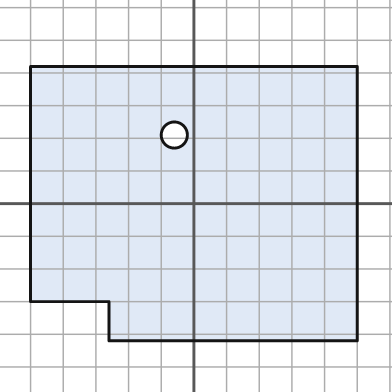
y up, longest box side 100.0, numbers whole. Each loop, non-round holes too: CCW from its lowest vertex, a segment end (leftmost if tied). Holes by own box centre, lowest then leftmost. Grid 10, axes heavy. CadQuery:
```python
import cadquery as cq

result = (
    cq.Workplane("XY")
    .moveTo(-26.0, -42.0)
    .lineTo(50.0, -42.0)
    .lineTo(50.0, 42.0)
    .lineTo(-50.0, 42.0)
    .lineTo(-50.0, -30.0)
    .lineTo(-26.0, -30.0)
    .close()
    .moveTo(-6.0, 21.0)
    .circle(4.0)
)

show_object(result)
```